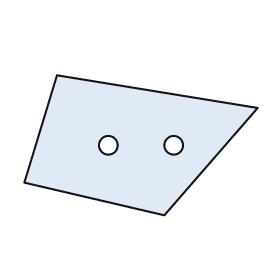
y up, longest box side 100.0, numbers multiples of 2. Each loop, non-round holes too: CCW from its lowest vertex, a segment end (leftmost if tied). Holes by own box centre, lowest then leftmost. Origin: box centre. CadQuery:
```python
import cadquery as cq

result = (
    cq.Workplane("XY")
    .moveTo(10.0, -30.0)
    .lineTo(50.0, 16.0)
    .lineTo(-36.0, 30.0)
    .lineTo(-50.0, -16.0)
    .close()
    .moveTo(-14.0, 0.0)
    .circle(4.0)
    .moveTo(14.0, 0.0)
    .circle(4.0)
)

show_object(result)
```